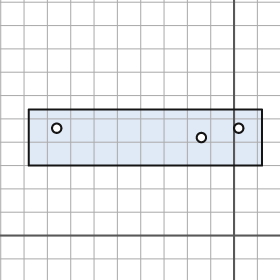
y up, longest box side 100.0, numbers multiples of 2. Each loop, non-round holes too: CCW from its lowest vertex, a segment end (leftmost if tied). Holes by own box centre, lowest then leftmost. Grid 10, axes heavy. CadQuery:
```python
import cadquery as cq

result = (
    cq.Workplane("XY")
    .moveTo(-88.0, 30.0)
    .lineTo(12.0, 30.0)
    .lineTo(12.0, 54.0)
    .lineTo(-88.0, 54.0)
    .close()
    .moveTo(-14.0, 42.0)
    .circle(2.0)
    .moveTo(-76.0, 46.0)
    .circle(2.0)
    .moveTo(2.0, 46.0)
    .circle(2.0)
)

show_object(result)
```